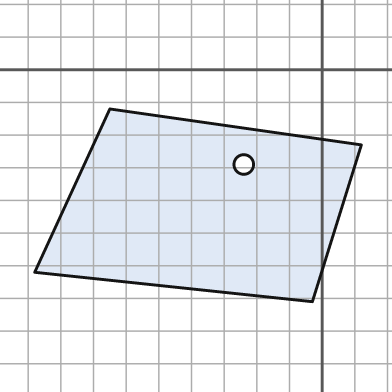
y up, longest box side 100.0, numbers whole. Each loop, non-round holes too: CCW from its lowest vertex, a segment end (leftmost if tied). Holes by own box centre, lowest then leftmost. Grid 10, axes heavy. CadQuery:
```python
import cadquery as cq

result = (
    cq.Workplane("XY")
    .moveTo(-3.0, -71.0)
    .lineTo(12.0, -23.0)
    .lineTo(-65.0, -12.0)
    .lineTo(-88.0, -62.0)
    .close()
    .moveTo(-24.0, -29.0)
    .circle(3.0)
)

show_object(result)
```